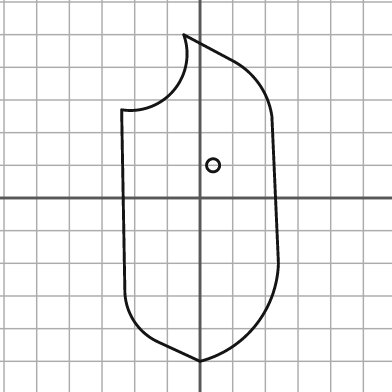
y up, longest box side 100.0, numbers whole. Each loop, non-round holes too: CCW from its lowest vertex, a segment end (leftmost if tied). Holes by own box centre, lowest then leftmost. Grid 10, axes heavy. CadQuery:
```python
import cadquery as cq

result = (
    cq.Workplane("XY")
    .moveTo(0.0, -50.0)
    .threePointArc((17.0, -39.0), (24.0, -20.0))
    .lineTo(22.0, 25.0)
    .threePointArc((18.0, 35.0), (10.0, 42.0))
    .lineTo(-5.0, 50.0)
    .threePointArc((-8.0, 33.0), (-24.0, 27.0))
    .lineTo(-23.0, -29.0)
    .threePointArc((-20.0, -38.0), (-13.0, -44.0))
    .close()
    .moveTo(4.0, 10.0)
    .circle(2.0)
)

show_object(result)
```